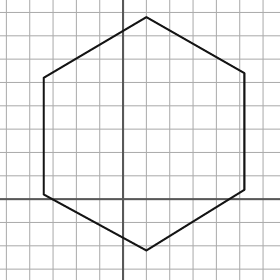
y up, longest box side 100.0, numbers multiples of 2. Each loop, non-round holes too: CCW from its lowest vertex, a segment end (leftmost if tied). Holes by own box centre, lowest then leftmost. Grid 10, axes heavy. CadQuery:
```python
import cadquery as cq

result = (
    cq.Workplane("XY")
    .moveTo(10.0, -22.0)
    .lineTo(52.0, 4.0)
    .lineTo(52.0, 54.0)
    .lineTo(10.0, 78.0)
    .lineTo(-34.0, 52.0)
    .lineTo(-34.0, 2.0)
    .close()
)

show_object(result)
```